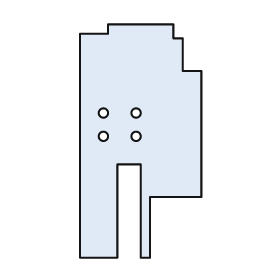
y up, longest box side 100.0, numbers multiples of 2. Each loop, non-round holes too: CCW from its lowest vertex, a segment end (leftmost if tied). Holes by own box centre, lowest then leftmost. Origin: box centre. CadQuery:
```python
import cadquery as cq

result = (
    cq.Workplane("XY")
    .moveTo(-26.0, -50.0)
    .lineTo(-10.0, -50.0)
    .lineTo(-10.0, -10.0)
    .lineTo(0.0, -10.0)
    .lineTo(0.0, -50.0)
    .lineTo(4.0, -50.0)
    .lineTo(4.0, -24.0)
    .lineTo(26.0, -24.0)
    .lineTo(26.0, 30.0)
    .lineTo(18.0, 30.0)
    .lineTo(18.0, 44.0)
    .lineTo(14.0, 44.0)
    .lineTo(14.0, 50.0)
    .lineTo(-14.0, 50.0)
    .lineTo(-14.0, 46.0)
    .lineTo(-26.0, 46.0)
    .close()
    .moveTo(-16.0, 2.0)
    .circle(2.0)
    .moveTo(-2.0, 2.0)
    .circle(2.0)
    .moveTo(-16.0, 12.0)
    .circle(2.0)
    .moveTo(-2.0, 12.0)
    .circle(2.0)
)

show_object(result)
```